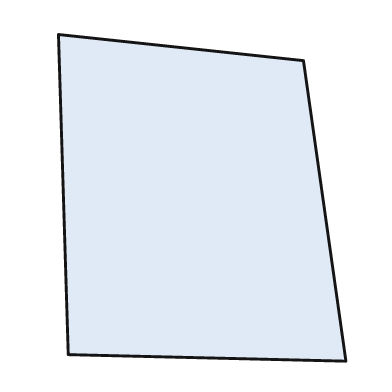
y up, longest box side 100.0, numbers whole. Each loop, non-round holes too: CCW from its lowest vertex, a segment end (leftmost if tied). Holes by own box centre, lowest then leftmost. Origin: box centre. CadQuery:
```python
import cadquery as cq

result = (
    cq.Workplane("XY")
    .moveTo(44.0, -50.0)
    .lineTo(31.0, 42.0)
    .lineTo(-44.0, 50.0)
    .lineTo(-41.0, -48.0)
    .close()
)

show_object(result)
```